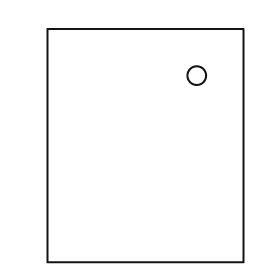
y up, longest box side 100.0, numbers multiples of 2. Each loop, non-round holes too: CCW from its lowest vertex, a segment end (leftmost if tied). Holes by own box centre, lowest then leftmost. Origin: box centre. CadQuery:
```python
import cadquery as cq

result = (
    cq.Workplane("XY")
    .moveTo(-42.0, -50.0)
    .lineTo(42.0, -50.0)
    .lineTo(42.0, 50.0)
    .lineTo(-42.0, 50.0)
    .close()
    .moveTo(22.0, 30.0)
    .circle(4.0)
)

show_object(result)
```